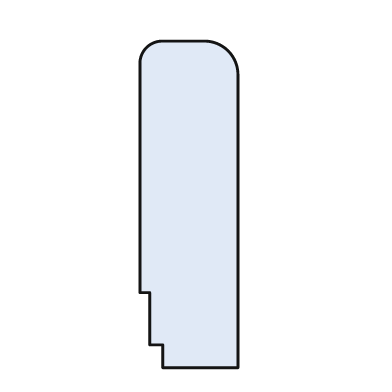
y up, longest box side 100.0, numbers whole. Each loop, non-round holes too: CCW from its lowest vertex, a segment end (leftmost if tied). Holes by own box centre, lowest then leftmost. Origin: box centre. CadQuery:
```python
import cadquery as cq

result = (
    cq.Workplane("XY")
    .moveTo(-8.0, -50.0)
    .lineTo(15.0, -50.0)
    .lineTo(15.0, 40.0)
    .threePointArc((12.0, 47.0), (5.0, 50.0))
    .lineTo(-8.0, 50.0)
    .threePointArc((-13.0, 48.0), (-15.0, 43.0))
    .lineTo(-15.0, -27.0)
    .lineTo(-12.0, -27.0)
    .lineTo(-12.0, -43.0)
    .lineTo(-8.0, -43.0)
    .close()
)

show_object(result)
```